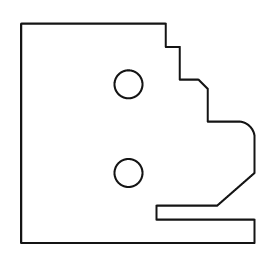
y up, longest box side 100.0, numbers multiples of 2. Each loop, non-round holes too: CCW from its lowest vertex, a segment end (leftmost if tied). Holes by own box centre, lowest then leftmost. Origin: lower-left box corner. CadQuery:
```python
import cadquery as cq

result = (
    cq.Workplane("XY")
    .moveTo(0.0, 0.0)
    .lineTo(100.0, 0.0)
    .lineTo(100.0, 10.0)
    .lineTo(58.0, 10.0)
    .lineTo(58.0, 16.0)
    .lineTo(84.0, 16.0)
    .lineTo(100.0, 30.0)
    .lineTo(100.0, 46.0)
    .threePointArc((98.0, 50.0), (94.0, 52.0))
    .lineTo(80.0, 52.0)
    .lineTo(80.0, 66.0)
    .lineTo(76.0, 70.0)
    .lineTo(68.0, 70.0)
    .lineTo(68.0, 84.0)
    .lineTo(62.0, 84.0)
    .lineTo(62.0, 94.0)
    .lineTo(0.0, 94.0)
    .close()
    .moveTo(46.0, 30.0)
    .circle(6.0)
    .moveTo(46.0, 68.0)
    .circle(6.0)
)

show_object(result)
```